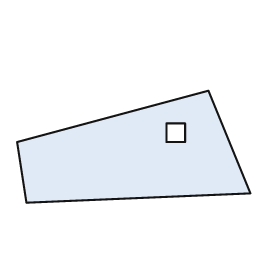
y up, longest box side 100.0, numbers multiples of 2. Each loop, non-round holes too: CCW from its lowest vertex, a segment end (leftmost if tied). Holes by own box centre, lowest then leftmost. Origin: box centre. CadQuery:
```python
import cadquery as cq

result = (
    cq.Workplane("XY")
    .moveTo(-46.0, -24.0)
    .lineTo(50.0, -20.0)
    .lineTo(32.0, 24.0)
    .lineTo(-50.0, 2.0)
    .close()
    .moveTo(14.0, 2.0)
    .lineTo(22.0, 2.0)
    .lineTo(22.0, 10.0)
    .lineTo(14.0, 10.0)
    .close()
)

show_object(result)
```